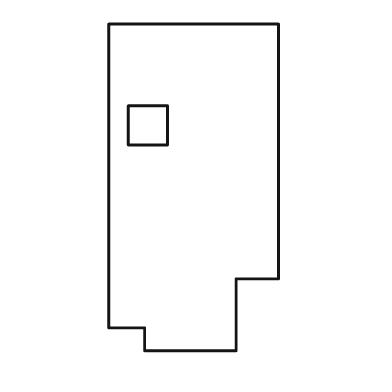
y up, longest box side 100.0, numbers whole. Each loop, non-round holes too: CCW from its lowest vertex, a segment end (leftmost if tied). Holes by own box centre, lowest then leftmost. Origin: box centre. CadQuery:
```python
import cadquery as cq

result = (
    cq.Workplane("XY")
    .moveTo(-15.0, -50.0)
    .lineTo(13.0, -50.0)
    .lineTo(13.0, -28.0)
    .lineTo(26.0, -28.0)
    .lineTo(26.0, 50.0)
    .lineTo(-26.0, 50.0)
    .lineTo(-26.0, -43.0)
    .lineTo(-15.0, -43.0)
    .close()
    .moveTo(-20.0, 13.0)
    .lineTo(-8.0, 13.0)
    .lineTo(-8.0, 25.0)
    .lineTo(-20.0, 25.0)
    .close()
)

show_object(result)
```